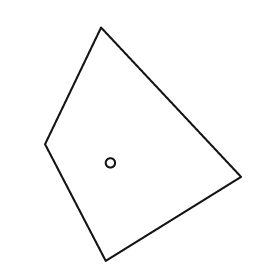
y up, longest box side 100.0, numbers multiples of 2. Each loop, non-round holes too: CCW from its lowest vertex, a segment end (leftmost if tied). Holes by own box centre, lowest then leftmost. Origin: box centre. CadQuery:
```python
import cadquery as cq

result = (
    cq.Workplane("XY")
    .moveTo(-16.0, -50.0)
    .lineTo(42.0, -14.0)
    .lineTo(-18.0, 50.0)
    .lineTo(-42.0, 0.0)
    .close()
    .moveTo(-14.0, -8.0)
    .circle(2.0)
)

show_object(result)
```